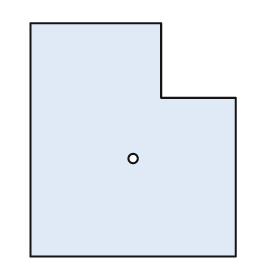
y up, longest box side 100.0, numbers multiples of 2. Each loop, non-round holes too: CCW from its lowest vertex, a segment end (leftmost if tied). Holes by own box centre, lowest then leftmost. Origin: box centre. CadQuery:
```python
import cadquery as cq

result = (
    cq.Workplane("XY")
    .moveTo(-44.0, -50.0)
    .lineTo(44.0, -50.0)
    .lineTo(44.0, 18.0)
    .lineTo(12.0, 18.0)
    .lineTo(12.0, 50.0)
    .lineTo(-44.0, 50.0)
    .close()
    .moveTo(0.0, -8.0)
    .circle(2.0)
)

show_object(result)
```